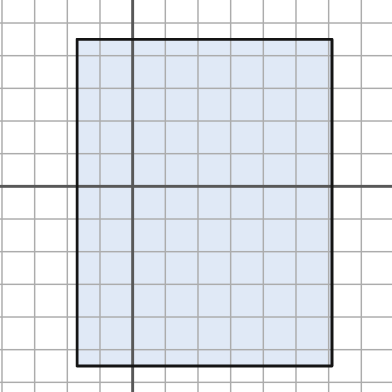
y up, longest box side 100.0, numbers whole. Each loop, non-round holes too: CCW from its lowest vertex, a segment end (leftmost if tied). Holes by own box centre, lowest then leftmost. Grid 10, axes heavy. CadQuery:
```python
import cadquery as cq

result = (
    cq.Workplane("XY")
    .moveTo(-17.0, -55.0)
    .lineTo(61.0, -55.0)
    .lineTo(61.0, 45.0)
    .lineTo(-17.0, 45.0)
    .close()
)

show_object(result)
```